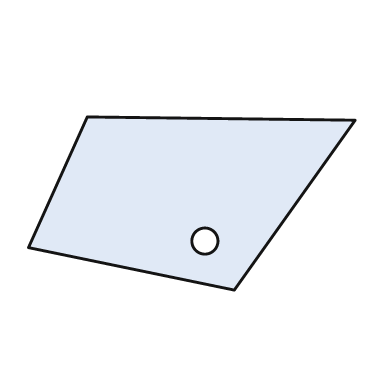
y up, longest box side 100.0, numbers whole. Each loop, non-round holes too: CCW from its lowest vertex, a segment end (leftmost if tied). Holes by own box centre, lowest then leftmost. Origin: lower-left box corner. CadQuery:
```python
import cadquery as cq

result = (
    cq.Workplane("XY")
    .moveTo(63.0, 0.0)
    .lineTo(100.0, 52.0)
    .lineTo(18.0, 53.0)
    .lineTo(0.0, 13.0)
    .close()
    .moveTo(54.0, 15.0)
    .circle(4.0)
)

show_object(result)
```